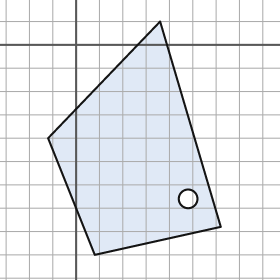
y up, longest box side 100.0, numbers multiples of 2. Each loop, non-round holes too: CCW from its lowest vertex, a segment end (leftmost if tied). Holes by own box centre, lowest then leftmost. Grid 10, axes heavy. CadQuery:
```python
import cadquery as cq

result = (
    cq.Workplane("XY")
    .moveTo(8.0, -90.0)
    .lineTo(62.0, -78.0)
    .lineTo(36.0, 10.0)
    .lineTo(-12.0, -40.0)
    .close()
    .moveTo(48.0, -66.0)
    .circle(4.0)
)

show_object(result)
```